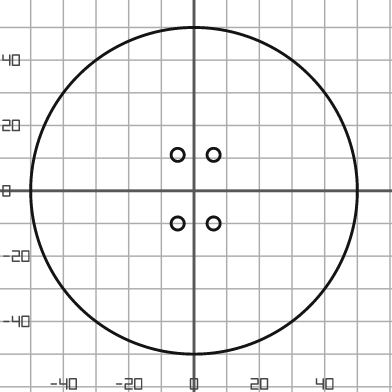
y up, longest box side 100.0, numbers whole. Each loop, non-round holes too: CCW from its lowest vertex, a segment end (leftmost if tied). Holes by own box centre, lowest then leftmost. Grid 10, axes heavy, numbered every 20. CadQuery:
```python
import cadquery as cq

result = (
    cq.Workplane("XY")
    .moveTo(0.0, 0.0)
    .circle(50.0)
    .moveTo(-5.0, -10.0)
    .circle(2.0)
    .moveTo(6.0, -10.0)
    .circle(2.0)
    .moveTo(-5.0, 11.0)
    .circle(2.0)
    .moveTo(6.0, 11.0)
    .circle(2.0)
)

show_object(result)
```